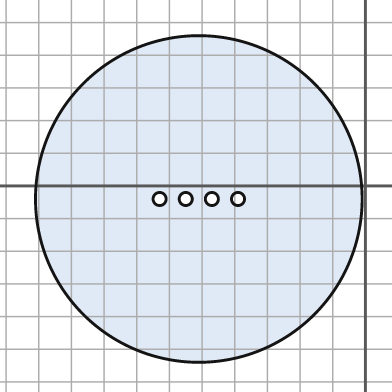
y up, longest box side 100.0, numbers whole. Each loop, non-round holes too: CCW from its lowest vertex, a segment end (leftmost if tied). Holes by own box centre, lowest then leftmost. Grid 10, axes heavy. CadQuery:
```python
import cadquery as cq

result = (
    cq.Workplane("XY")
    .moveTo(-51.0, -4.0)
    .circle(50.0)
    .moveTo(-63.0, -4.0)
    .circle(2.0)
    .moveTo(-55.0, -4.0)
    .circle(2.0)
    .moveTo(-47.0, -4.0)
    .circle(2.0)
    .moveTo(-39.0, -4.0)
    .circle(2.0)
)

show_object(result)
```